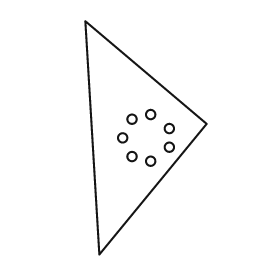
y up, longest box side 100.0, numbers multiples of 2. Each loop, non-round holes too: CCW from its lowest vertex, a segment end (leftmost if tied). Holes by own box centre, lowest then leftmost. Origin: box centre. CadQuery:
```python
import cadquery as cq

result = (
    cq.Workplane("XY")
    .moveTo(-20.0, -50.0)
    .lineTo(26.0, 6.0)
    .lineTo(-26.0, 50.0)
    .close()
    .moveTo(2.0, -10.0)
    .circle(2.0)
    .moveTo(-6.0, -8.0)
    .circle(2.0)
    .moveTo(10.0, -4.0)
    .circle(2.0)
    .moveTo(-10.0, 0.0)
    .circle(2.0)
    .moveTo(10.0, 4.0)
    .circle(2.0)
    .moveTo(-6.0, 8.0)
    .circle(2.0)
    .moveTo(2.0, 10.0)
    .circle(2.0)
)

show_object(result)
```